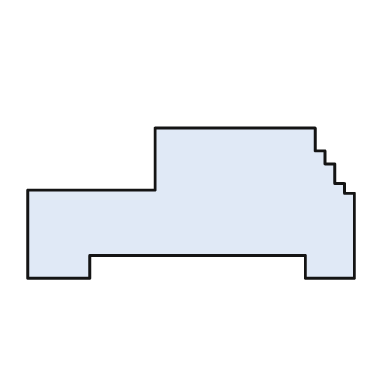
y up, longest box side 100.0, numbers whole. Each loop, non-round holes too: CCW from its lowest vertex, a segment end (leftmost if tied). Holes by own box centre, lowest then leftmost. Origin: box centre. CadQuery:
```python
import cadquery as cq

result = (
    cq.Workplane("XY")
    .moveTo(-50.0, -23.0)
    .lineTo(-31.0, -23.0)
    .lineTo(-31.0, -16.0)
    .lineTo(35.0, -16.0)
    .lineTo(35.0, -23.0)
    .lineTo(50.0, -23.0)
    .lineTo(50.0, 3.0)
    .lineTo(47.0, 3.0)
    .lineTo(47.0, 6.0)
    .lineTo(44.0, 6.0)
    .lineTo(44.0, 12.0)
    .lineTo(41.0, 12.0)
    .lineTo(41.0, 16.0)
    .lineTo(38.0, 16.0)
    .lineTo(38.0, 23.0)
    .lineTo(-11.0, 23.0)
    .lineTo(-11.0, 4.0)
    .lineTo(-50.0, 4.0)
    .close()
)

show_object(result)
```